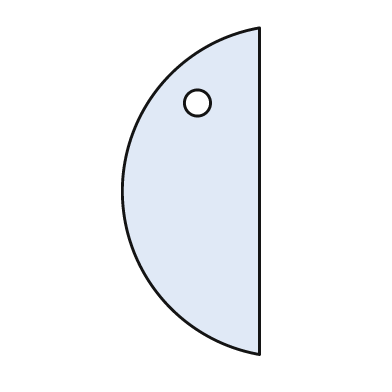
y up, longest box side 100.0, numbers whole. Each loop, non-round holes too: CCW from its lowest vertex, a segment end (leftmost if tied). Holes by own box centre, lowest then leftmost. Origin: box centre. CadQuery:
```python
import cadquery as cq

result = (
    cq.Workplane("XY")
    .moveTo(21.0, -50.0)
    .lineTo(21.0, 50.0)
    .threePointArc((-21.0, 0.0), (21.0, -50.0))
    .close()
    .moveTo(2.0, 27.0)
    .circle(4.0)
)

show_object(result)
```